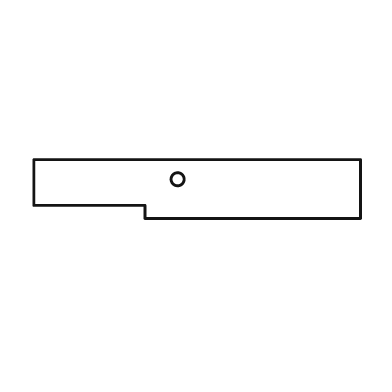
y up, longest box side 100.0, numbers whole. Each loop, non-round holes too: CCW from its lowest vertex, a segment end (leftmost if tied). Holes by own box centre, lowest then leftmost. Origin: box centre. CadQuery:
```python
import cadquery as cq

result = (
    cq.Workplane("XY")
    .moveTo(-16.0, -9.0)
    .lineTo(50.0, -9.0)
    .lineTo(50.0, 9.0)
    .lineTo(-50.0, 9.0)
    .lineTo(-50.0, -5.0)
    .lineTo(-16.0, -5.0)
    .close()
    .moveTo(-6.0, 3.0)
    .circle(2.0)
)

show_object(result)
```